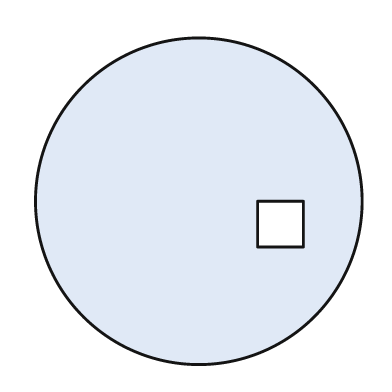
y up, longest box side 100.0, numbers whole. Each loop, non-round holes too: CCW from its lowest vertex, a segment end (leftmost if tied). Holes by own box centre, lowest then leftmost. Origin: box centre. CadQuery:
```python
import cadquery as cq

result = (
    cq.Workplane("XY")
    .moveTo(0.0, 0.0)
    .circle(50.0)
    .moveTo(18.0, -14.0)
    .lineTo(32.0, -14.0)
    .lineTo(32.0, 0.0)
    .lineTo(18.0, 0.0)
    .close()
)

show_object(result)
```